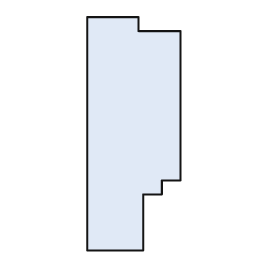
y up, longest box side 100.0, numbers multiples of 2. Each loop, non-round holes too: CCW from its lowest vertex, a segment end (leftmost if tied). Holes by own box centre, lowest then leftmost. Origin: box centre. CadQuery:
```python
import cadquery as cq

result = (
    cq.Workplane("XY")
    .moveTo(-20.0, -50.0)
    .lineTo(4.0, -50.0)
    .lineTo(4.0, -26.0)
    .lineTo(12.0, -26.0)
    .lineTo(12.0, -20.0)
    .lineTo(20.0, -20.0)
    .lineTo(20.0, 44.0)
    .lineTo(2.0, 44.0)
    .lineTo(2.0, 50.0)
    .lineTo(-20.0, 50.0)
    .close()
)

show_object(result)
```